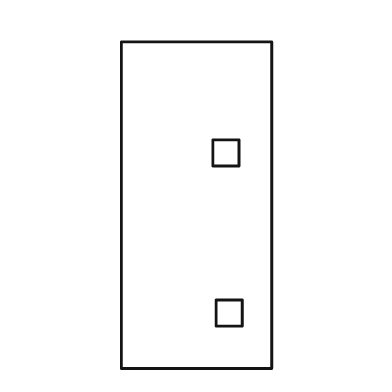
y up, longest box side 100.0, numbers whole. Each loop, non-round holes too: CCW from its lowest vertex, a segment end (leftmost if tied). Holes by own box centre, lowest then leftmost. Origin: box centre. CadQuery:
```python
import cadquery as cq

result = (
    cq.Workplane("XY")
    .moveTo(-23.0, -50.0)
    .lineTo(23.0, -50.0)
    .lineTo(23.0, 50.0)
    .lineTo(-23.0, 50.0)
    .close()
    .moveTo(6.0, -37.0)
    .lineTo(14.0, -37.0)
    .lineTo(14.0, -29.0)
    .lineTo(6.0, -29.0)
    .close()
    .moveTo(5.0, 12.0)
    .lineTo(13.0, 12.0)
    .lineTo(13.0, 20.0)
    .lineTo(5.0, 20.0)
    .close()
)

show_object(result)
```